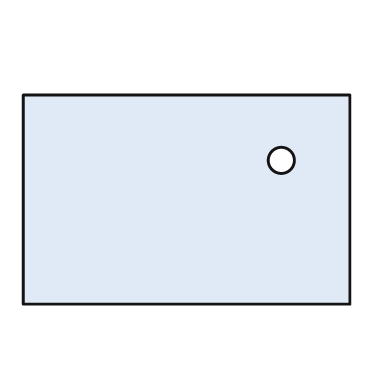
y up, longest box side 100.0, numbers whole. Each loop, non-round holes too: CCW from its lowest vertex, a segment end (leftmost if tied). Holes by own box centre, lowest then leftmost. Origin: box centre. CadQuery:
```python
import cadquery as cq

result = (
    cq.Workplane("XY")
    .moveTo(-50.0, -32.0)
    .lineTo(50.0, -32.0)
    .lineTo(50.0, 32.0)
    .lineTo(-50.0, 32.0)
    .close()
    .moveTo(29.0, 12.0)
    .circle(4.0)
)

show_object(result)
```